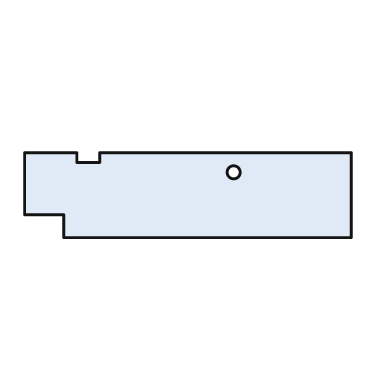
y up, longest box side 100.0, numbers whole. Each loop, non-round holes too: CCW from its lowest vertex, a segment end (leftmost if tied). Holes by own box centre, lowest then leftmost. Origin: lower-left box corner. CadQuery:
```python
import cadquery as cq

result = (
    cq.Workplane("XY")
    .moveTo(12.0, 0.0)
    .lineTo(100.0, 0.0)
    .lineTo(100.0, 26.0)
    .lineTo(23.0, 26.0)
    .lineTo(23.0, 23.0)
    .lineTo(16.0, 23.0)
    .lineTo(16.0, 26.0)
    .lineTo(0.0, 26.0)
    .lineTo(0.0, 7.0)
    .lineTo(12.0, 7.0)
    .close()
    .moveTo(64.0, 20.0)
    .circle(2.0)
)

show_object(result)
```